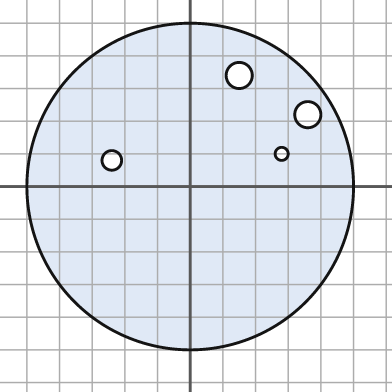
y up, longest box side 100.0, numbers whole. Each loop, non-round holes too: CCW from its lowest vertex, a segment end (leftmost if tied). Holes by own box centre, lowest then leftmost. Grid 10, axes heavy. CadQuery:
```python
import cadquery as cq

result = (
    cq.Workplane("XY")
    .moveTo(0.0, 0.0)
    .circle(50.0)
    .moveTo(-24.0, 8.0)
    .circle(3.0)
    .moveTo(28.0, 10.0)
    .circle(2.0)
    .moveTo(36.0, 22.0)
    .circle(4.0)
    .moveTo(15.0, 34.0)
    .circle(4.0)
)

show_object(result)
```